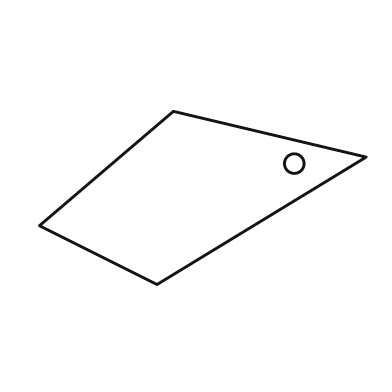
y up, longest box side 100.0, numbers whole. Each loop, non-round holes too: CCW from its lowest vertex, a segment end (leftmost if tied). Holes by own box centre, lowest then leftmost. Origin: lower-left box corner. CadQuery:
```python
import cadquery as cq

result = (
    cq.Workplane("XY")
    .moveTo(36.0, 0.0)
    .lineTo(100.0, 39.0)
    .lineTo(41.0, 53.0)
    .lineTo(0.0, 18.0)
    .close()
    .moveTo(78.0, 37.0)
    .circle(3.0)
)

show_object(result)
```